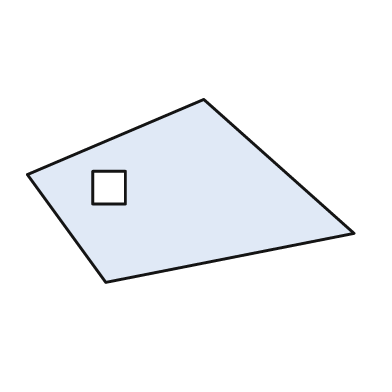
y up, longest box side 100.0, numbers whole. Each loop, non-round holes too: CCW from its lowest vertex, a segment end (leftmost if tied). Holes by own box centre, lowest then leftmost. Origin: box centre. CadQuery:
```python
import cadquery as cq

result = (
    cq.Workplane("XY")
    .moveTo(-26.0, -28.0)
    .lineTo(50.0, -13.0)
    .lineTo(4.0, 28.0)
    .lineTo(-50.0, 5.0)
    .close()
    .moveTo(-30.0, -4.0)
    .lineTo(-20.0, -4.0)
    .lineTo(-20.0, 6.0)
    .lineTo(-30.0, 6.0)
    .close()
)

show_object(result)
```